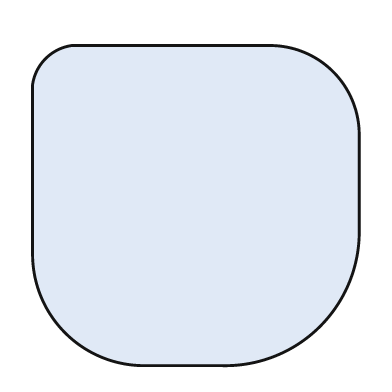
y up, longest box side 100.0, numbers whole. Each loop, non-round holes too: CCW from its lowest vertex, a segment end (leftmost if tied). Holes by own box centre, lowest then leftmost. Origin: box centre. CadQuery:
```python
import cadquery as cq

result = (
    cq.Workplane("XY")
    .moveTo(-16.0, -49.0)
    .lineTo(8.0, -49.0)
    .threePointArc((38.0, -37.0), (50.0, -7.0))
    .lineTo(50.0, 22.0)
    .threePointArc((42.0, 41.0), (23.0, 49.0))
    .lineTo(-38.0, 49.0)
    .threePointArc((-46.0, 45.0), (-50.0, 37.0))
    .lineTo(-50.0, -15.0)
    .threePointArc((-40.0, -39.0), (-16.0, -49.0))
    .close()
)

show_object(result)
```